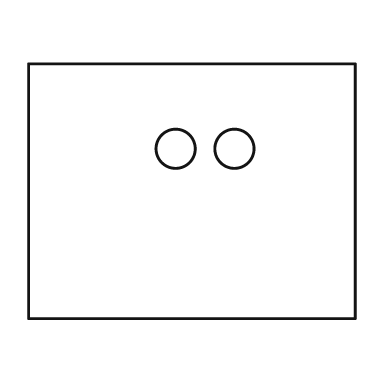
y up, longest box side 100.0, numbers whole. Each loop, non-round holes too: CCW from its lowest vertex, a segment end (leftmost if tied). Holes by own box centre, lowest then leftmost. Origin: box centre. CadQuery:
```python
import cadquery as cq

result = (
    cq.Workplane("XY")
    .moveTo(-50.0, -39.0)
    .lineTo(50.0, -39.0)
    .lineTo(50.0, 39.0)
    .lineTo(-50.0, 39.0)
    .close()
    .moveTo(-5.0, 13.0)
    .circle(6.0)
    .moveTo(13.0, 13.0)
    .circle(6.0)
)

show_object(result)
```